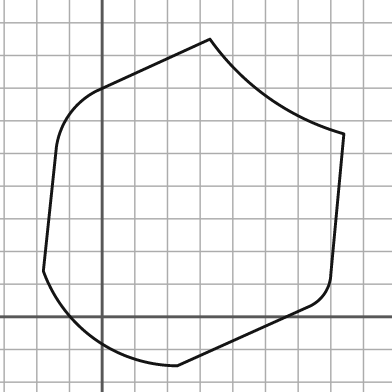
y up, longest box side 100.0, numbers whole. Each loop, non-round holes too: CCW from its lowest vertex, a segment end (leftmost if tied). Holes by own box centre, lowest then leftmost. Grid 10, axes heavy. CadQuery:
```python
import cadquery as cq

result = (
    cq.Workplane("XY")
    .moveTo(23.0, -15.0)
    .lineTo(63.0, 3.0)
    .threePointArc((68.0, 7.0), (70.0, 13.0))
    .lineTo(74.0, 56.0)
    .threePointArc((51.0, 67.0), (33.0, 85.0))
    .lineTo(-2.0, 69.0)
    .threePointArc((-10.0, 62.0), (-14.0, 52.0))
    .lineTo(-18.0, 14.0)
    .threePointArc((-2.0, -7.0), (23.0, -15.0))
    .close()
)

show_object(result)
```